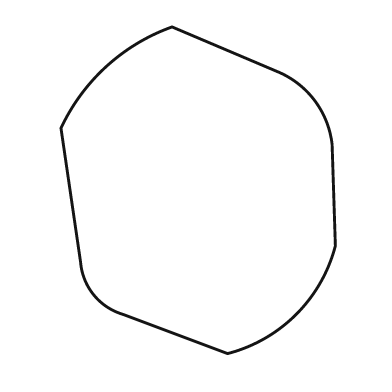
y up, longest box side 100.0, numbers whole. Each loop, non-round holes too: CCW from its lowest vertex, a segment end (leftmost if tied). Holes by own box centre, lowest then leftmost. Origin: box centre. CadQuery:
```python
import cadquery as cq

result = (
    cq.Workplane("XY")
    .moveTo(9.0, -50.0)
    .threePointArc((30.0, -38.0), (42.0, -17.0))
    .lineTo(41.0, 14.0)
    .threePointArc((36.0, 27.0), (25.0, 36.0))
    .lineTo(-8.0, 50.0)
    .threePointArc((-28.0, 38.0), (-42.0, 19.0))
    .lineTo(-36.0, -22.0)
    .threePointArc((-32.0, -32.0), (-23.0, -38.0))
    .close()
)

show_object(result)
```